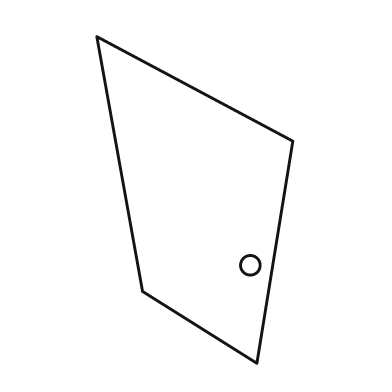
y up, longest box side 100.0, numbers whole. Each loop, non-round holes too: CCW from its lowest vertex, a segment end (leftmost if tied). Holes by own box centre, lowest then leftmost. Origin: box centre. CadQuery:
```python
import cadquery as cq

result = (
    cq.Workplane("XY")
    .moveTo(19.0, -50.0)
    .lineTo(30.0, 18.0)
    .lineTo(-30.0, 50.0)
    .lineTo(-16.0, -28.0)
    .close()
    .moveTo(17.0, -20.0)
    .circle(3.0)
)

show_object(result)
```